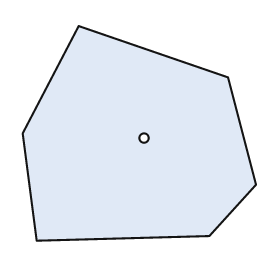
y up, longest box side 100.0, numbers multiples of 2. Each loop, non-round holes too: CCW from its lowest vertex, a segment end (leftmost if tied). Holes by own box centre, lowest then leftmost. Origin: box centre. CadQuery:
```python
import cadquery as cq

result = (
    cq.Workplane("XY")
    .moveTo(-44.0, -46.0)
    .lineTo(30.0, -44.0)
    .lineTo(50.0, -22.0)
    .lineTo(38.0, 24.0)
    .lineTo(-26.0, 46.0)
    .lineTo(-50.0, 0.0)
    .close()
    .moveTo(2.0, -2.0)
    .circle(2.0)
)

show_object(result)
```